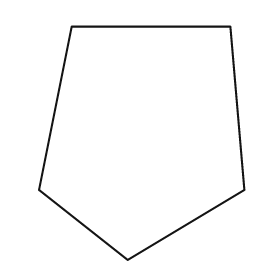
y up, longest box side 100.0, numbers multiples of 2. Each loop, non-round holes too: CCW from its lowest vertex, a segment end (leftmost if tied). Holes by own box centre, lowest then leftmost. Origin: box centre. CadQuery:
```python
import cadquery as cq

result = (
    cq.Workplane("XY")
    .moveTo(-6.0, -50.0)
    .lineTo(44.0, -20.0)
    .lineTo(38.0, 50.0)
    .lineTo(-30.0, 50.0)
    .lineTo(-44.0, -20.0)
    .close()
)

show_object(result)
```